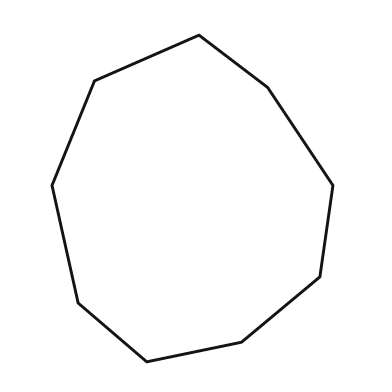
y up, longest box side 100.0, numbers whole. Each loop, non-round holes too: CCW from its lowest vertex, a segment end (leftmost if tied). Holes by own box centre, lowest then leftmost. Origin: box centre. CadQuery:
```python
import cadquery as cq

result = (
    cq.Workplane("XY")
    .moveTo(-14.0, -50.0)
    .lineTo(15.0, -44.0)
    .lineTo(39.0, -24.0)
    .lineTo(43.0, 4.0)
    .lineTo(23.0, 34.0)
    .lineTo(2.0, 50.0)
    .lineTo(-30.0, 36.0)
    .lineTo(-43.0, 4.0)
    .lineTo(-35.0, -32.0)
    .close()
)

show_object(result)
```